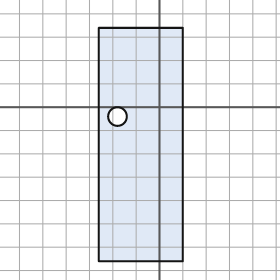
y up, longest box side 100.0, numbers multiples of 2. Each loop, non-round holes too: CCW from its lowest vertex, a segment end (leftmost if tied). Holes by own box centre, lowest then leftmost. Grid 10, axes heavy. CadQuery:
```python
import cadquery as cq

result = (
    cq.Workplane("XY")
    .moveTo(-26.0, -66.0)
    .lineTo(10.0, -66.0)
    .lineTo(10.0, 34.0)
    .lineTo(-26.0, 34.0)
    .close()
    .moveTo(-18.0, -4.0)
    .circle(4.0)
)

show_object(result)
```